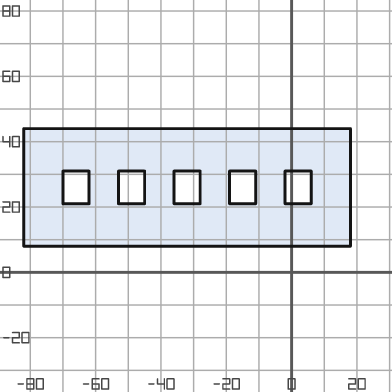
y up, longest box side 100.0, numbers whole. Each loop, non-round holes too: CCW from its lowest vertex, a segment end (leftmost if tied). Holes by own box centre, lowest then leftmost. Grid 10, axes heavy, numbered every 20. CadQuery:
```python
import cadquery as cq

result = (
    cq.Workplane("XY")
    .moveTo(-82.0, 8.0)
    .lineTo(18.0, 8.0)
    .lineTo(18.0, 44.0)
    .lineTo(-82.0, 44.0)
    .close()
    .moveTo(-70.0, 21.0)
    .lineTo(-62.0, 21.0)
    .lineTo(-62.0, 31.0)
    .lineTo(-70.0, 31.0)
    .close()
    .moveTo(-53.0, 21.0)
    .lineTo(-45.0, 21.0)
    .lineTo(-45.0, 31.0)
    .lineTo(-53.0, 31.0)
    .close()
    .moveTo(-36.0, 21.0)
    .lineTo(-28.0, 21.0)
    .lineTo(-28.0, 31.0)
    .lineTo(-36.0, 31.0)
    .close()
    .moveTo(-19.0, 21.0)
    .lineTo(-11.0, 21.0)
    .lineTo(-11.0, 31.0)
    .lineTo(-19.0, 31.0)
    .close()
    .moveTo(-2.0, 21.0)
    .lineTo(6.0, 21.0)
    .lineTo(6.0, 31.0)
    .lineTo(-2.0, 31.0)
    .close()
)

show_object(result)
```